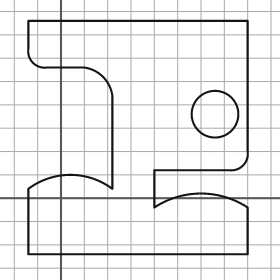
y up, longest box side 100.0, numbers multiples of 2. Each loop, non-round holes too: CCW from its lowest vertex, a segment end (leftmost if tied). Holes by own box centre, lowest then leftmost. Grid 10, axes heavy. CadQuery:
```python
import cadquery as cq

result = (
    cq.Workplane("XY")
    .moveTo(-14.0, -24.0)
    .lineTo(80.0, -24.0)
    .lineTo(80.0, -4.0)
    .threePointArc((60.0, 2.0), (40.0, -4.0))
    .lineTo(40.0, 12.0)
    .lineTo(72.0, 12.0)
    .threePointArc((78.0, 14.0), (80.0, 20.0))
    .lineTo(80.0, 76.0)
    .lineTo(-14.0, 76.0)
    .lineTo(-14.0, 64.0)
    .threePointArc((-12.0, 58.0), (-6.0, 56.0))
    .lineTo(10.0, 56.0)
    .threePointArc((18.0, 52.0), (22.0, 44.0))
    .lineTo(22.0, 4.0)
    .threePointArc((4.0, 10.0), (-14.0, 4.0))
    .close()
    .moveTo(66.0, 36.0)
    .circle(10.0)
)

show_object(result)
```